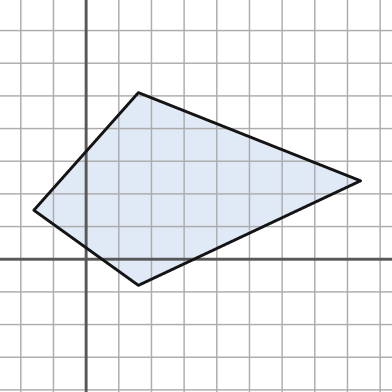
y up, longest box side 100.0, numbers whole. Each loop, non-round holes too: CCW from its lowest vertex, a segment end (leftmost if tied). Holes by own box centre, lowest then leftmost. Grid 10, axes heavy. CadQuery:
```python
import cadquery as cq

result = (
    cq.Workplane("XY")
    .moveTo(16.0, -8.0)
    .lineTo(84.0, 24.0)
    .lineTo(16.0, 51.0)
    .lineTo(-16.0, 15.0)
    .close()
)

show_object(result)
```